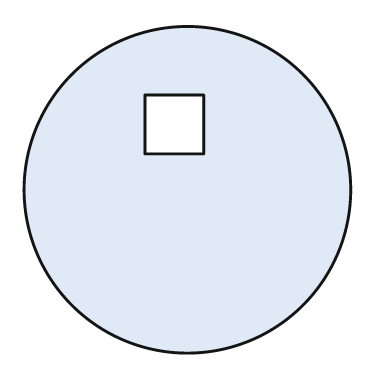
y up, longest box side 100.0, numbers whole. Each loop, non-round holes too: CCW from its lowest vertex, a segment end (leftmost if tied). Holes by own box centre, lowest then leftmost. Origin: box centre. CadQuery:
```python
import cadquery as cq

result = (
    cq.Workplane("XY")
    .moveTo(0.0, 0.0)
    .circle(50.0)
    .moveTo(-13.0, 11.0)
    .lineTo(5.0, 11.0)
    .lineTo(5.0, 29.0)
    .lineTo(-13.0, 29.0)
    .close()
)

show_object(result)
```